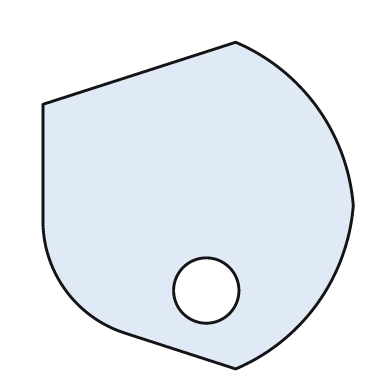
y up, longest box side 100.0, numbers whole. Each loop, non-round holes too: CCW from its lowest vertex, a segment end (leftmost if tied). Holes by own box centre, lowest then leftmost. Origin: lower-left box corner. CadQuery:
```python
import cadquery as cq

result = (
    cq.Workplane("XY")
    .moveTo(59.0, 0.0)
    .threePointArc((84.0, 20.0), (95.0, 50.0))
    .threePointArc((84.0, 80.0), (59.0, 100.0))
    .lineTo(0.0, 81.0)
    .lineTo(0.0, 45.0)
    .threePointArc((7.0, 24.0), (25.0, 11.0))
    .close()
    .moveTo(50.0, 24.0)
    .circle(10.0)
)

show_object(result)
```